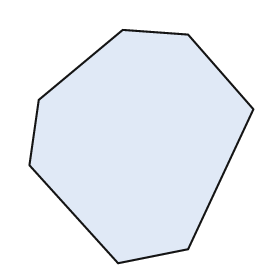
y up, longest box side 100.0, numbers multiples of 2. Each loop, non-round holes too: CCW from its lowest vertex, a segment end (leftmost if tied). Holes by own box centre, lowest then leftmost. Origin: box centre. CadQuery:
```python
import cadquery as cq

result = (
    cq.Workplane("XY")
    .moveTo(-10.0, -50.0)
    .lineTo(20.0, -44.0)
    .lineTo(48.0, 16.0)
    .lineTo(20.0, 48.0)
    .lineTo(-8.0, 50.0)
    .lineTo(-44.0, 20.0)
    .lineTo(-48.0, -8.0)
    .close()
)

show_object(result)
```